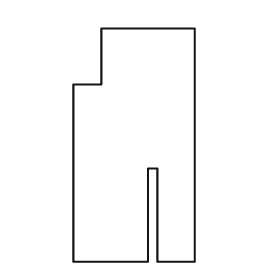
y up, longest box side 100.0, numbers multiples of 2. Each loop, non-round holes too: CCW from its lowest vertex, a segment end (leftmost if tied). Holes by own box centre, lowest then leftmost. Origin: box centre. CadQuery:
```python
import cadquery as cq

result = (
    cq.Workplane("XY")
    .moveTo(-26.0, -50.0)
    .lineTo(6.0, -50.0)
    .lineTo(6.0, -10.0)
    .lineTo(10.0, -10.0)
    .lineTo(10.0, -50.0)
    .lineTo(26.0, -50.0)
    .lineTo(26.0, 50.0)
    .lineTo(-14.0, 50.0)
    .lineTo(-14.0, 26.0)
    .lineTo(-26.0, 26.0)
    .close()
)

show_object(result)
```